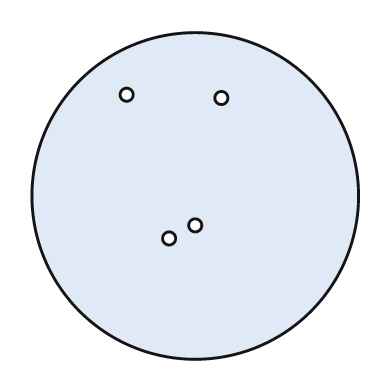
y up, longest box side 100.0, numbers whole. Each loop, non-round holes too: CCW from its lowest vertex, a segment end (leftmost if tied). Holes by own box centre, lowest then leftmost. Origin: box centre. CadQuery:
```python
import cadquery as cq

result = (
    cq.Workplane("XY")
    .moveTo(0.0, 0.0)
    .circle(50.0)
    .moveTo(-8.0, -13.0)
    .circle(2.0)
    .moveTo(0.0, -9.0)
    .circle(2.0)
    .moveTo(8.0, 30.0)
    .circle(2.0)
    .moveTo(-21.0, 31.0)
    .circle(2.0)
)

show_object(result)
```